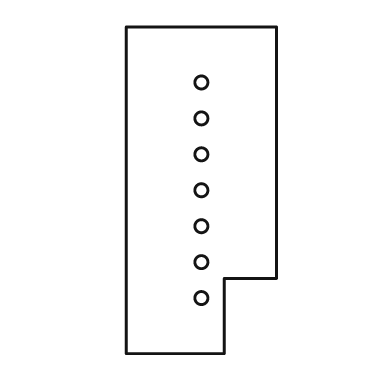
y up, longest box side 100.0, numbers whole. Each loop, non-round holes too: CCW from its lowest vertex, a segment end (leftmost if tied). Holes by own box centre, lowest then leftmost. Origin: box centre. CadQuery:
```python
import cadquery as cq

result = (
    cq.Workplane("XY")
    .moveTo(-23.0, -50.0)
    .lineTo(7.0, -50.0)
    .lineTo(7.0, -27.0)
    .lineTo(23.0, -27.0)
    .lineTo(23.0, 50.0)
    .lineTo(-23.0, 50.0)
    .close()
    .moveTo(0.0, -33.0)
    .circle(2.0)
    .moveTo(0.0, -22.0)
    .circle(2.0)
    .moveTo(0.0, -11.0)
    .circle(2.0)
    .moveTo(0.0, 0.0)
    .circle(2.0)
    .moveTo(0.0, 11.0)
    .circle(2.0)
    .moveTo(0.0, 22.0)
    .circle(2.0)
    .moveTo(0.0, 33.0)
    .circle(2.0)
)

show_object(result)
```